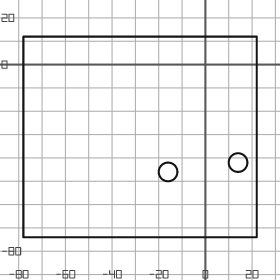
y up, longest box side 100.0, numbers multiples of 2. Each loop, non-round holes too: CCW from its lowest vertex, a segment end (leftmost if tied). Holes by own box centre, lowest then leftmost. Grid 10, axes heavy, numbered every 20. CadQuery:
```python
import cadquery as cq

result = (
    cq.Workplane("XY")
    .moveTo(-78.0, -74.0)
    .lineTo(22.0, -74.0)
    .lineTo(22.0, 12.0)
    .lineTo(-78.0, 12.0)
    .close()
    .moveTo(-16.0, -46.0)
    .circle(4.0)
    .moveTo(14.0, -42.0)
    .circle(4.0)
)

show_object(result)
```